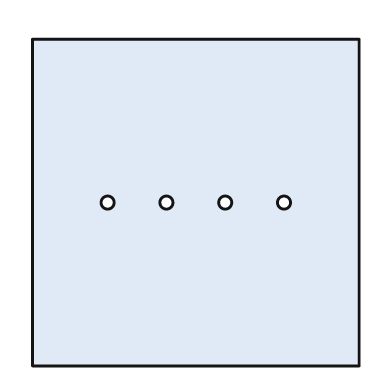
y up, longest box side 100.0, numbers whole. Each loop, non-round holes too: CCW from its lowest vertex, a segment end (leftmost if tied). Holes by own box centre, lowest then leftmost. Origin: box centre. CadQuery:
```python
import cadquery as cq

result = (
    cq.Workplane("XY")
    .moveTo(-50.0, -50.0)
    .lineTo(50.0, -50.0)
    .lineTo(50.0, 50.0)
    .lineTo(-50.0, 50.0)
    .close()
    .moveTo(-27.0, 0.0)
    .circle(2.0)
    .moveTo(-9.0, 0.0)
    .circle(2.0)
    .moveTo(9.0, 0.0)
    .circle(2.0)
    .moveTo(27.0, 0.0)
    .circle(2.0)
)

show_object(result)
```